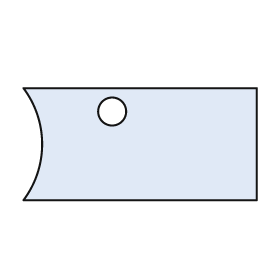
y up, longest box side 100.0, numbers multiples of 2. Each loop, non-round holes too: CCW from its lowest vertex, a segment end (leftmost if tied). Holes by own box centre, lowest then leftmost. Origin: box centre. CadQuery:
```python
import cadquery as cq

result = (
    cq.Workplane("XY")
    .moveTo(-50.0, -24.0)
    .lineTo(50.0, -24.0)
    .lineTo(50.0, 24.0)
    .lineTo(-50.0, 24.0)
    .threePointArc((-42.0, 0.0), (-50.0, -24.0))
    .close()
    .moveTo(-12.0, 14.0)
    .circle(6.0)
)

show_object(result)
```